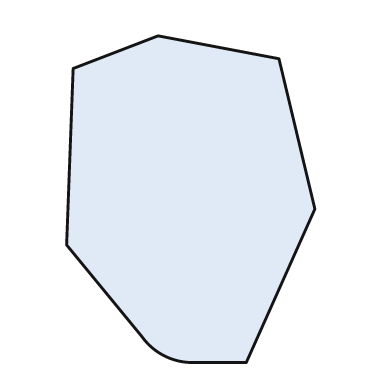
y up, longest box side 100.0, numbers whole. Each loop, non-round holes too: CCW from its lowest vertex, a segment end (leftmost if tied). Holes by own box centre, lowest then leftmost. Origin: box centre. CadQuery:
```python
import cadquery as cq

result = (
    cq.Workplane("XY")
    .moveTo(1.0, -50.0)
    .lineTo(17.0, -50.0)
    .lineTo(38.0, -3.0)
    .lineTo(27.0, 43.0)
    .lineTo(-10.0, 50.0)
    .lineTo(-36.0, 40.0)
    .lineTo(-38.0, -14.0)
    .lineTo(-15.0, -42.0)
    .threePointArc((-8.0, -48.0), (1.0, -50.0))
    .close()
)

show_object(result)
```